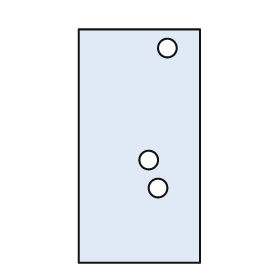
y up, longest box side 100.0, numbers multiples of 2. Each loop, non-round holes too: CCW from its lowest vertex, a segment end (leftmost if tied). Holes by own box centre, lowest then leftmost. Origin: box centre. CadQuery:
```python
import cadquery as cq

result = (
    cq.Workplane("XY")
    .moveTo(-26.0, -50.0)
    .lineTo(26.0, -50.0)
    .lineTo(26.0, 50.0)
    .lineTo(-26.0, 50.0)
    .close()
    .moveTo(8.0, -18.0)
    .circle(4.0)
    .moveTo(4.0, -6.0)
    .circle(4.0)
    .moveTo(12.0, 42.0)
    .circle(4.0)
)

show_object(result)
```